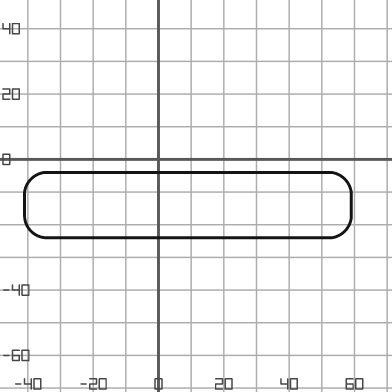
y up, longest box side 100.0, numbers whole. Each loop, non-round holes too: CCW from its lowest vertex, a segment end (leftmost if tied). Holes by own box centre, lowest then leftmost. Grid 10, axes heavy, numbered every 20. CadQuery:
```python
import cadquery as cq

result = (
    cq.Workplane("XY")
    .moveTo(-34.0, -24.0)
    .lineTo(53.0, -24.0)
    .threePointArc((57.0, -22.0), (59.0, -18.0))
    .lineTo(59.0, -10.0)
    .threePointArc((57.0, -6.0), (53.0, -4.0))
    .lineTo(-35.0, -4.0)
    .threePointArc((-39.0, -6.0), (-41.0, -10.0))
    .lineTo(-41.0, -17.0)
    .threePointArc((-39.0, -22.0), (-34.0, -24.0))
    .close()
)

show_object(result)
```